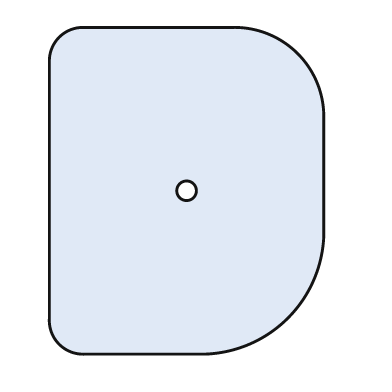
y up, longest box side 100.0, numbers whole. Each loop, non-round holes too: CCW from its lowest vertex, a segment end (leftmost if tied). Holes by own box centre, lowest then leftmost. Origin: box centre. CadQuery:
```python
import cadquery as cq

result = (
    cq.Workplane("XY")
    .moveTo(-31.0, -50.0)
    .lineTo(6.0, -50.0)
    .threePointArc((31.0, -39.0), (42.0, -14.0))
    .lineTo(42.0, 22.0)
    .threePointArc((34.0, 42.0), (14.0, 50.0))
    .lineTo(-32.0, 50.0)
    .threePointArc((-39.0, 47.0), (-42.0, 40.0))
    .lineTo(-42.0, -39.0)
    .threePointArc((-39.0, -47.0), (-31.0, -50.0))
    .close()
    .moveTo(0.0, 0.0)
    .circle(3.0)
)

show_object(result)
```